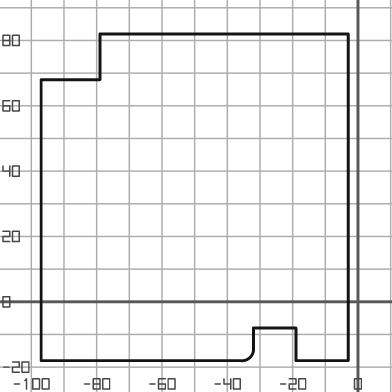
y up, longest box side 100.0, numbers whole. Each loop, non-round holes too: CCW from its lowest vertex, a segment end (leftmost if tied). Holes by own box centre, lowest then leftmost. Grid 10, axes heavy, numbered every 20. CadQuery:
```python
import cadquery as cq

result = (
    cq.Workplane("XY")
    .moveTo(-97.0, -18.0)
    .lineTo(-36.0, -18.0)
    .threePointArc((-33.0, -17.0), (-32.0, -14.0))
    .lineTo(-32.0, -8.0)
    .lineTo(-19.0, -8.0)
    .lineTo(-19.0, -18.0)
    .lineTo(-3.0, -18.0)
    .lineTo(-3.0, 82.0)
    .lineTo(-79.0, 82.0)
    .lineTo(-79.0, 68.0)
    .lineTo(-97.0, 68.0)
    .close()
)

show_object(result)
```